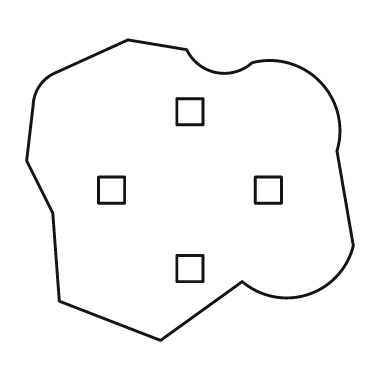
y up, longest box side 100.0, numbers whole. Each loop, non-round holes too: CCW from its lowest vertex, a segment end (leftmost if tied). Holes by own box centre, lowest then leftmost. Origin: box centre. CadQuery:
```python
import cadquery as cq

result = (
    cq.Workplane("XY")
    .moveTo(-9.0, -46.0)
    .lineTo(16.0, -28.0)
    .threePointArc((36.0, -32.0), (50.0, -17.0))
    .lineTo(45.0, 12.0)
    .threePointArc((40.0, 33.0), (19.0, 39.0))
    .threePointArc((8.0, 36.0), (-1.0, 43.0))
    .lineTo(-19.0, 46.0)
    .lineTo(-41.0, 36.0)
    .threePointArc((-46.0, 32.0), (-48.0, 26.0))
    .lineTo(-50.0, 9.0)
    .lineTo(-42.0, -7.0)
    .lineTo(-40.0, -34.0)
    .close()
    .moveTo(-4.0, -28.0)
    .lineTo(4.0, -28.0)
    .lineTo(4.0, -20.0)
    .lineTo(-4.0, -20.0)
    .close()
    .moveTo(-28.0, -4.0)
    .lineTo(-20.0, -4.0)
    .lineTo(-20.0, 4.0)
    .lineTo(-28.0, 4.0)
    .close()
    .moveTo(20.0, -4.0)
    .lineTo(28.0, -4.0)
    .lineTo(28.0, 4.0)
    .lineTo(20.0, 4.0)
    .close()
    .moveTo(-4.0, 20.0)
    .lineTo(4.0, 20.0)
    .lineTo(4.0, 28.0)
    .lineTo(-4.0, 28.0)
    .close()
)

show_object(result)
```